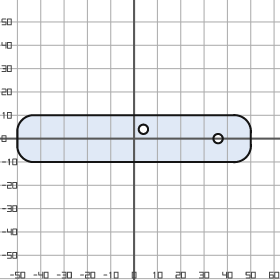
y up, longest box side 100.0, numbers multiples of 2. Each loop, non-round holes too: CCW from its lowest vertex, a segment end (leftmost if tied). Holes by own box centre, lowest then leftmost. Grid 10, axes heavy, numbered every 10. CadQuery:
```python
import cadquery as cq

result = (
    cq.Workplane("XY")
    .moveTo(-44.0, -10.0)
    .lineTo(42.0, -10.0)
    .threePointArc((48.0, -8.0), (50.0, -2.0))
    .lineTo(50.0, 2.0)
    .threePointArc((48.0, 8.0), (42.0, 10.0))
    .lineTo(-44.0, 10.0)
    .threePointArc((-48.0, 8.0), (-50.0, 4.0))
    .lineTo(-50.0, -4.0)
    .threePointArc((-48.0, -8.0), (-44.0, -10.0))
    .close()
    .moveTo(36.0, 0.0)
    .circle(2.0)
    .moveTo(4.0, 4.0)
    .circle(2.0)
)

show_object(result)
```